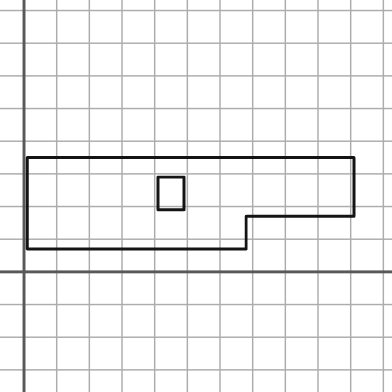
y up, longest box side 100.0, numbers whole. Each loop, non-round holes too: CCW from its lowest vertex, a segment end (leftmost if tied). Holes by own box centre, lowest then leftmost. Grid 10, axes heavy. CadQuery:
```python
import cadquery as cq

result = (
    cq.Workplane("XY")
    .moveTo(1.0, 7.0)
    .lineTo(68.0, 7.0)
    .lineTo(68.0, 17.0)
    .lineTo(101.0, 17.0)
    .lineTo(101.0, 35.0)
    .lineTo(1.0, 35.0)
    .close()
    .moveTo(41.0, 19.0)
    .lineTo(49.0, 19.0)
    .lineTo(49.0, 29.0)
    .lineTo(41.0, 29.0)
    .close()
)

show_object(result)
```